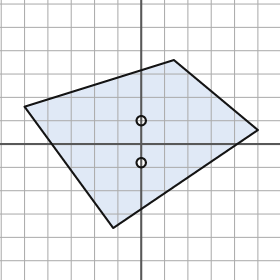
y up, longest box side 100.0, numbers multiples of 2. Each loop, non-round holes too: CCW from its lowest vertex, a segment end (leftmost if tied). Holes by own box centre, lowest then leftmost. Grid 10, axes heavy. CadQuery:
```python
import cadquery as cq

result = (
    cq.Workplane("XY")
    .moveTo(-12.0, -36.0)
    .lineTo(50.0, 6.0)
    .lineTo(14.0, 36.0)
    .lineTo(-50.0, 16.0)
    .close()
    .moveTo(0.0, -8.0)
    .circle(2.0)
    .moveTo(0.0, 10.0)
    .circle(2.0)
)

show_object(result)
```